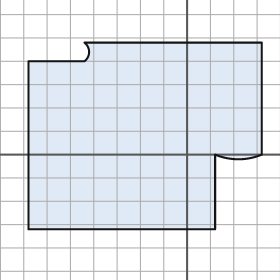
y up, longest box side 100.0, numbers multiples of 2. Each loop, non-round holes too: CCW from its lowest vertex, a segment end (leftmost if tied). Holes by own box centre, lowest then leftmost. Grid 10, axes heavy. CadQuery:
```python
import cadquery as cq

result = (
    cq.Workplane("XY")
    .moveTo(-68.0, -32.0)
    .lineTo(12.0, -32.0)
    .lineTo(12.0, 0.0)
    .threePointArc((22.0, -2.0), (32.0, 0.0))
    .lineTo(32.0, 48.0)
    .lineTo(-44.0, 48.0)
    .threePointArc((-42.0, 44.0), (-44.0, 40.0))
    .lineTo(-68.0, 40.0)
    .close()
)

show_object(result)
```